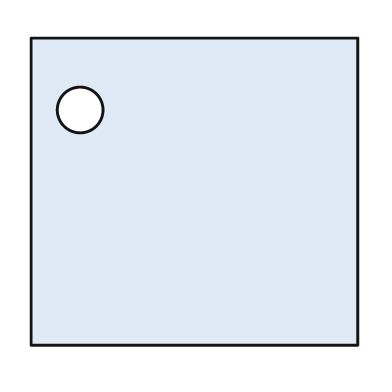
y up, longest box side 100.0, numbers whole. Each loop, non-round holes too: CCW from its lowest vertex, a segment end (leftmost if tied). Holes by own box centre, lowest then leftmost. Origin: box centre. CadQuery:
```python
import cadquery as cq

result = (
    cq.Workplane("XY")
    .moveTo(-50.0, -47.0)
    .lineTo(50.0, -47.0)
    .lineTo(50.0, 47.0)
    .lineTo(-50.0, 47.0)
    .close()
    .moveTo(-35.0, 25.0)
    .circle(7.0)
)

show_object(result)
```